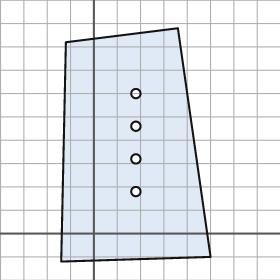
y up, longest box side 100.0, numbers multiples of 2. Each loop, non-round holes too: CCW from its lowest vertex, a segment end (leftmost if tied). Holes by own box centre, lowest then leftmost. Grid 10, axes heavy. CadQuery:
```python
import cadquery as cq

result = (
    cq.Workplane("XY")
    .moveTo(-14.0, -12.0)
    .lineTo(50.0, -10.0)
    .lineTo(36.0, 88.0)
    .lineTo(-12.0, 82.0)
    .close()
    .moveTo(18.0, 18.0)
    .circle(2.0)
    .moveTo(18.0, 32.0)
    .circle(2.0)
    .moveTo(18.0, 46.0)
    .circle(2.0)
    .moveTo(18.0, 60.0)
    .circle(2.0)
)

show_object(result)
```